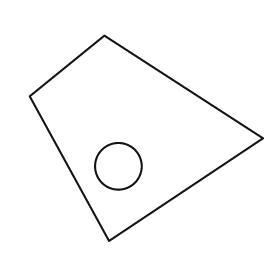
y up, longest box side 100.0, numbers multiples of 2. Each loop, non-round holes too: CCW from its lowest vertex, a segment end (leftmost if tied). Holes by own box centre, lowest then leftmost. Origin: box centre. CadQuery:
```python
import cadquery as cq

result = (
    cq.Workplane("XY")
    .moveTo(-16.0, -44.0)
    .lineTo(50.0, 0.0)
    .lineTo(-18.0, 44.0)
    .lineTo(-50.0, 18.0)
    .close()
    .moveTo(-12.0, -12.0)
    .circle(10.0)
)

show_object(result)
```